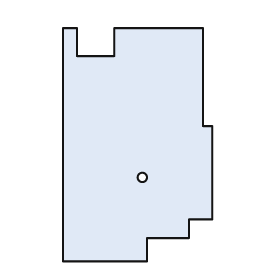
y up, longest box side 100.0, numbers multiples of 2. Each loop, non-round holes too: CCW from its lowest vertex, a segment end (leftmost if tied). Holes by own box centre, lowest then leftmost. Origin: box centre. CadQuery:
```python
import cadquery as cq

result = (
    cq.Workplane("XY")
    .moveTo(-32.0, -50.0)
    .lineTo(4.0, -50.0)
    .lineTo(4.0, -40.0)
    .lineTo(22.0, -40.0)
    .lineTo(22.0, -32.0)
    .lineTo(32.0, -32.0)
    .lineTo(32.0, 8.0)
    .lineTo(28.0, 8.0)
    .lineTo(28.0, 50.0)
    .lineTo(-10.0, 50.0)
    .lineTo(-10.0, 38.0)
    .lineTo(-26.0, 38.0)
    .lineTo(-26.0, 50.0)
    .lineTo(-32.0, 50.0)
    .close()
    .moveTo(2.0, -14.0)
    .circle(2.0)
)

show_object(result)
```